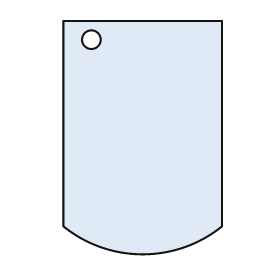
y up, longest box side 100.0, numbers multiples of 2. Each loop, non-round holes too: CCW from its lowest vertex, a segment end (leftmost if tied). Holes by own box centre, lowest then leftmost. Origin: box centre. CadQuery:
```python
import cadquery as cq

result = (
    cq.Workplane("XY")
    .moveTo(-34.0, -38.0)
    .threePointArc((0.0, -50.0), (34.0, -38.0))
    .lineTo(34.0, 50.0)
    .lineTo(-34.0, 50.0)
    .close()
    .moveTo(-22.0, 42.0)
    .circle(4.0)
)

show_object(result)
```